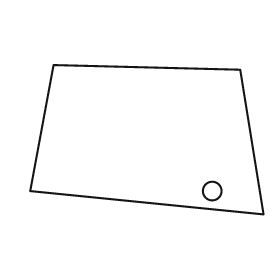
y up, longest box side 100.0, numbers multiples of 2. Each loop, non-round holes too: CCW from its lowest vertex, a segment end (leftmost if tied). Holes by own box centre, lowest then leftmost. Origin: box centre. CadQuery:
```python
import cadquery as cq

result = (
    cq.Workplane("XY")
    .moveTo(50.0, -32.0)
    .lineTo(40.0, 30.0)
    .lineTo(-40.0, 32.0)
    .lineTo(-50.0, -22.0)
    .close()
    .moveTo(28.0, -22.0)
    .circle(4.0)
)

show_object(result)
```